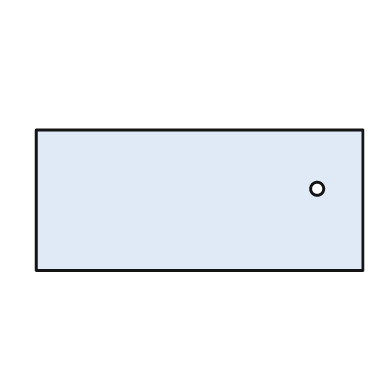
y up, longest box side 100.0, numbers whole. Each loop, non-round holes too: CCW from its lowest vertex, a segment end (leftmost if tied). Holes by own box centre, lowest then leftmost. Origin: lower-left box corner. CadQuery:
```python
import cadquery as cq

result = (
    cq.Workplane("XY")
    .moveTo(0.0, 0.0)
    .lineTo(100.0, 0.0)
    .lineTo(100.0, 43.0)
    .lineTo(0.0, 43.0)
    .close()
    .moveTo(86.0, 25.0)
    .circle(2.0)
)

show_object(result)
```